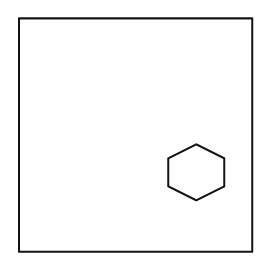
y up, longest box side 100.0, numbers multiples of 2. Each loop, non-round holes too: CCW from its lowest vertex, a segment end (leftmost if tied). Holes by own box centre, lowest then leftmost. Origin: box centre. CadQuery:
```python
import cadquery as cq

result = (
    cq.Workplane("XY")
    .moveTo(-50.0, -50.0)
    .lineTo(50.0, -50.0)
    .lineTo(50.0, 50.0)
    .lineTo(-50.0, 50.0)
    .close()
    .moveTo(26.0, -28.0)
    .lineTo(38.0, -22.0)
    .lineTo(38.0, -10.0)
    .lineTo(26.0, -4.0)
    .lineTo(14.0, -10.0)
    .lineTo(14.0, -22.0)
    .close()
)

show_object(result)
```